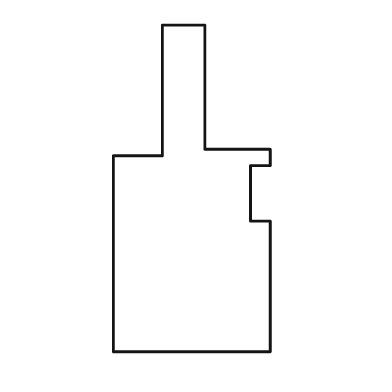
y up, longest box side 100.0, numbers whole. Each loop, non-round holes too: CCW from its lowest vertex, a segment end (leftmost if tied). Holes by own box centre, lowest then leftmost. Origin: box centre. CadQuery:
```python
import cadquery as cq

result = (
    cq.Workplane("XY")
    .moveTo(-24.0, -50.0)
    .lineTo(24.0, -50.0)
    .lineTo(24.0, -10.0)
    .lineTo(18.0, -10.0)
    .lineTo(18.0, 7.0)
    .lineTo(24.0, 7.0)
    .lineTo(24.0, 12.0)
    .lineTo(4.0, 12.0)
    .lineTo(4.0, 50.0)
    .lineTo(-9.0, 50.0)
    .lineTo(-9.0, 10.0)
    .lineTo(-24.0, 10.0)
    .close()
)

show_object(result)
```